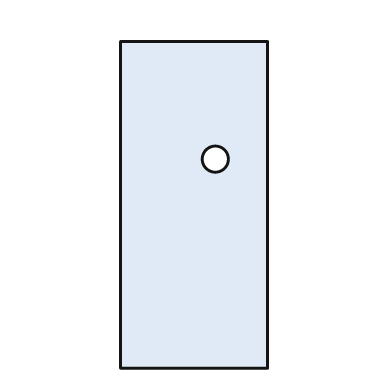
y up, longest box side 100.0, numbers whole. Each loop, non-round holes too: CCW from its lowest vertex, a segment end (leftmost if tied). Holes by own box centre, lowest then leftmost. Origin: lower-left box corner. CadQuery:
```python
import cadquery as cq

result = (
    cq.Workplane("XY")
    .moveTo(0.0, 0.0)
    .lineTo(45.0, 0.0)
    .lineTo(45.0, 100.0)
    .lineTo(0.0, 100.0)
    .close()
    .moveTo(29.0, 64.0)
    .circle(4.0)
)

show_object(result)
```